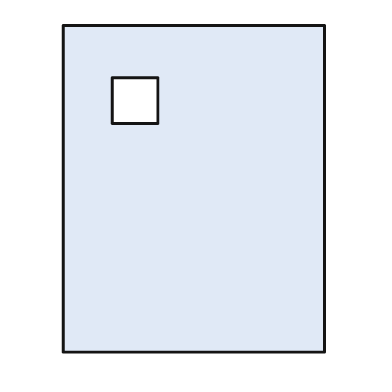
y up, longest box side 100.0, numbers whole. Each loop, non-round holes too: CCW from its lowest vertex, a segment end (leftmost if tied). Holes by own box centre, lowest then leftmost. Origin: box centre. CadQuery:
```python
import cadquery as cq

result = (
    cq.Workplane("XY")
    .moveTo(-40.0, -50.0)
    .lineTo(40.0, -50.0)
    .lineTo(40.0, 50.0)
    .lineTo(-40.0, 50.0)
    .close()
    .moveTo(-25.0, 20.0)
    .lineTo(-11.0, 20.0)
    .lineTo(-11.0, 34.0)
    .lineTo(-25.0, 34.0)
    .close()
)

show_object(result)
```